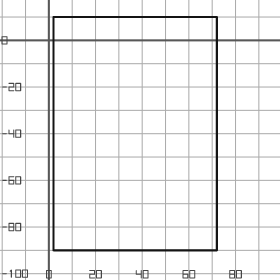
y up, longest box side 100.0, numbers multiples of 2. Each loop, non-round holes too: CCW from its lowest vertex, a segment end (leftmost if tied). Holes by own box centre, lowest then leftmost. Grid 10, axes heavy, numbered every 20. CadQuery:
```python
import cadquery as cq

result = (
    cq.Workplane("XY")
    .moveTo(2.0, -90.0)
    .lineTo(72.0, -90.0)
    .lineTo(72.0, 10.0)
    .lineTo(2.0, 10.0)
    .close()
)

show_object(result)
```